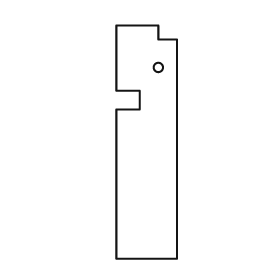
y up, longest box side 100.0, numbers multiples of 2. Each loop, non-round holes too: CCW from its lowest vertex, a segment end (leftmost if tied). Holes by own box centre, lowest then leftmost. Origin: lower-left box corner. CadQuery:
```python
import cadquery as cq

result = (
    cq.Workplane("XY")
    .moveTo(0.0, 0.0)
    .lineTo(26.0, 0.0)
    .lineTo(26.0, 94.0)
    .lineTo(18.0, 94.0)
    .lineTo(18.0, 100.0)
    .lineTo(0.0, 100.0)
    .lineTo(0.0, 72.0)
    .lineTo(10.0, 72.0)
    .lineTo(10.0, 64.0)
    .lineTo(0.0, 64.0)
    .close()
    .moveTo(18.0, 82.0)
    .circle(2.0)
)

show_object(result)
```